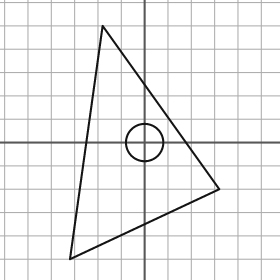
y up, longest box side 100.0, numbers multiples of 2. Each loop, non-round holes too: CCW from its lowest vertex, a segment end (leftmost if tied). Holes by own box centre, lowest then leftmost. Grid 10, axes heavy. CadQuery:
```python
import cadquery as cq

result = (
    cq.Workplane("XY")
    .moveTo(-32.0, -50.0)
    .lineTo(32.0, -20.0)
    .lineTo(-18.0, 50.0)
    .close()
    .moveTo(0.0, 0.0)
    .circle(8.0)
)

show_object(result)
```